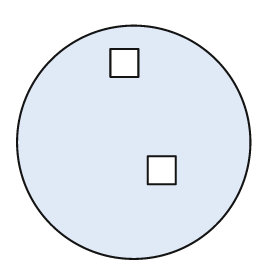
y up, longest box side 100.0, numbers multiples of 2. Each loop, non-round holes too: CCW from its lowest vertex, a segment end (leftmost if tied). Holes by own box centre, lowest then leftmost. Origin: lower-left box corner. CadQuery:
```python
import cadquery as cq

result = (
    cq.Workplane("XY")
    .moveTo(50.0, 50.0)
    .circle(50.0)
    .moveTo(56.0, 32.0)
    .lineTo(68.0, 32.0)
    .lineTo(68.0, 44.0)
    .lineTo(56.0, 44.0)
    .close()
    .moveTo(40.0, 78.0)
    .lineTo(52.0, 78.0)
    .lineTo(52.0, 90.0)
    .lineTo(40.0, 90.0)
    .close()
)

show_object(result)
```